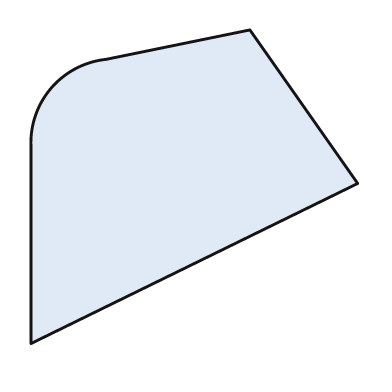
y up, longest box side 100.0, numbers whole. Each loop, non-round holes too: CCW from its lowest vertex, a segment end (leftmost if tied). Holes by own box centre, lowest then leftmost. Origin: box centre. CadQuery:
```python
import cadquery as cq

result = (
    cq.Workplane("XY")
    .moveTo(-50.0, -48.0)
    .lineTo(50.0, 1.0)
    .lineTo(17.0, 48.0)
    .lineTo(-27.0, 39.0)
    .threePointArc((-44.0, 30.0), (-50.0, 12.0))
    .close()
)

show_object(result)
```